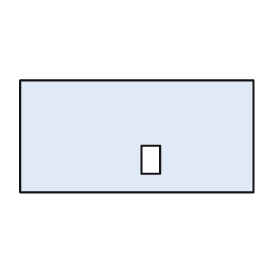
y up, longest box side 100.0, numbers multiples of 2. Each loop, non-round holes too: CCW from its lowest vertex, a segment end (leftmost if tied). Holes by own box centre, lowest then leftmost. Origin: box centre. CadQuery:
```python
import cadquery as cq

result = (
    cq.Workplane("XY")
    .moveTo(-50.0, -24.0)
    .lineTo(50.0, -24.0)
    .lineTo(50.0, 24.0)
    .lineTo(-50.0, 24.0)
    .close()
    .moveTo(2.0, -16.0)
    .lineTo(10.0, -16.0)
    .lineTo(10.0, -4.0)
    .lineTo(2.0, -4.0)
    .close()
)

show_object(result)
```